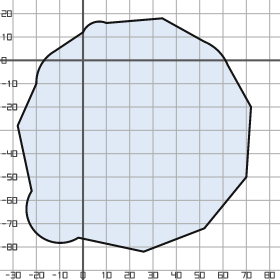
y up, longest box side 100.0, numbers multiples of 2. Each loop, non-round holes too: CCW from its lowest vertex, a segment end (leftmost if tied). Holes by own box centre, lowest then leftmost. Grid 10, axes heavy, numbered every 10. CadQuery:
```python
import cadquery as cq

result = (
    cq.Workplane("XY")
    .moveTo(26.0, -82.0)
    .lineTo(52.0, -72.0)
    .lineTo(70.0, -50.0)
    .lineTo(72.0, -20.0)
    .lineTo(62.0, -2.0)
    .threePointArc((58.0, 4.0), (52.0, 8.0))
    .lineTo(34.0, 18.0)
    .lineTo(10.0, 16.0)
    .threePointArc((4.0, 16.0), (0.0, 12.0))
    .lineTo(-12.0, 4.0)
    .threePointArc((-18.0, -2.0), (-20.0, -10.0))
    .lineTo(-28.0, -28.0)
    .lineTo(-22.0, -56.0)
    .threePointArc((-20.0, -74.0), (-2.0, -76.0))
    .close()
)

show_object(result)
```